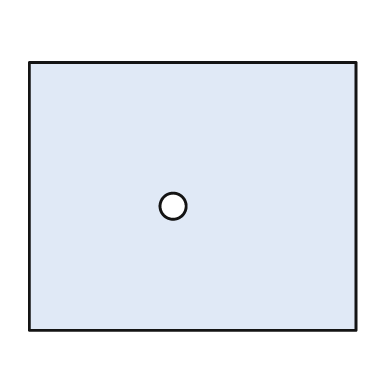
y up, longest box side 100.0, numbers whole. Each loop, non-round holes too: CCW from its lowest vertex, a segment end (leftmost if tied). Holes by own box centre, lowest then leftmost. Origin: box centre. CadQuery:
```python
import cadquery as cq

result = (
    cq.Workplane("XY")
    .moveTo(-50.0, -41.0)
    .lineTo(50.0, -41.0)
    .lineTo(50.0, 41.0)
    .lineTo(-50.0, 41.0)
    .close()
    .moveTo(-6.0, -3.0)
    .circle(4.0)
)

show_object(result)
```